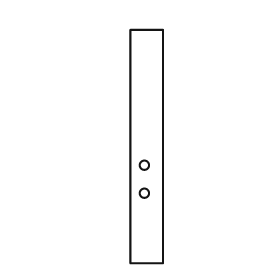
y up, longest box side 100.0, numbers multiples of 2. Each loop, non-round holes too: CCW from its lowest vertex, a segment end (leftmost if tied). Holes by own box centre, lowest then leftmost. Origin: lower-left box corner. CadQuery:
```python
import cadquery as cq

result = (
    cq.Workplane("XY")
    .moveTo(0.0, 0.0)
    .lineTo(14.0, 0.0)
    .lineTo(14.0, 100.0)
    .lineTo(0.0, 100.0)
    .close()
    .moveTo(6.0, 30.0)
    .circle(2.0)
    .moveTo(6.0, 42.0)
    .circle(2.0)
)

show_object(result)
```